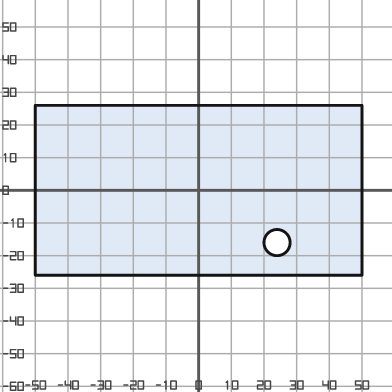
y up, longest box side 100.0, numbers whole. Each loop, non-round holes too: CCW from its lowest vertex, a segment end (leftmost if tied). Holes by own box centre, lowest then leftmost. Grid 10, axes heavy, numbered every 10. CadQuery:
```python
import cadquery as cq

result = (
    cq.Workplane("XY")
    .moveTo(-50.0, -26.0)
    .lineTo(50.0, -26.0)
    .lineTo(50.0, 26.0)
    .lineTo(-50.0, 26.0)
    .close()
    .moveTo(24.0, -16.0)
    .circle(4.0)
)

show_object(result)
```